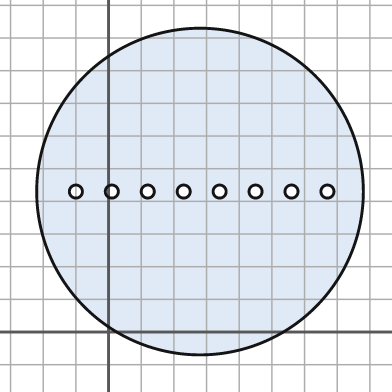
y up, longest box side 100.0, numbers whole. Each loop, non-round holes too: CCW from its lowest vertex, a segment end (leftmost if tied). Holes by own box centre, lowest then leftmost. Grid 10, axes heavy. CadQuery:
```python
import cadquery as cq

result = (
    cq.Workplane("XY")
    .moveTo(28.0, 43.0)
    .circle(50.0)
    .moveTo(-10.0, 43.0)
    .circle(2.0)
    .moveTo(1.0, 43.0)
    .circle(2.0)
    .moveTo(12.0, 43.0)
    .circle(2.0)
    .moveTo(23.0, 43.0)
    .circle(2.0)
    .moveTo(34.0, 43.0)
    .circle(2.0)
    .moveTo(45.0, 43.0)
    .circle(2.0)
    .moveTo(56.0, 43.0)
    .circle(2.0)
    .moveTo(67.0, 43.0)
    .circle(2.0)
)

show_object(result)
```